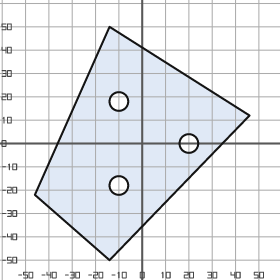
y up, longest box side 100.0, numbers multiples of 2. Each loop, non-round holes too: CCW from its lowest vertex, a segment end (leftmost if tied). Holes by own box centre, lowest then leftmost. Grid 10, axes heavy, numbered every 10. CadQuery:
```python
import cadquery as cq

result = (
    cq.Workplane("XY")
    .moveTo(-14.0, -50.0)
    .lineTo(46.0, 12.0)
    .lineTo(-14.0, 50.0)
    .lineTo(-46.0, -22.0)
    .close()
    .moveTo(-10.0, -18.0)
    .circle(4.0)
    .moveTo(20.0, 0.0)
    .circle(4.0)
    .moveTo(-10.0, 18.0)
    .circle(4.0)
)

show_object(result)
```